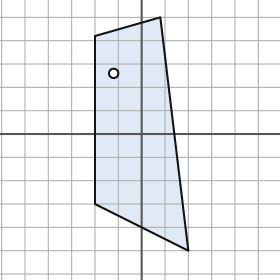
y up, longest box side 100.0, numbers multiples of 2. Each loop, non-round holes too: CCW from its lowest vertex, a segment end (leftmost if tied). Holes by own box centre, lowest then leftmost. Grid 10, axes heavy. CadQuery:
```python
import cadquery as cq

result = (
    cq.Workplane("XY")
    .moveTo(20.0, -50.0)
    .lineTo(8.0, 50.0)
    .lineTo(-20.0, 42.0)
    .lineTo(-20.0, -30.0)
    .close()
    .moveTo(-12.0, 26.0)
    .circle(2.0)
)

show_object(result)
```